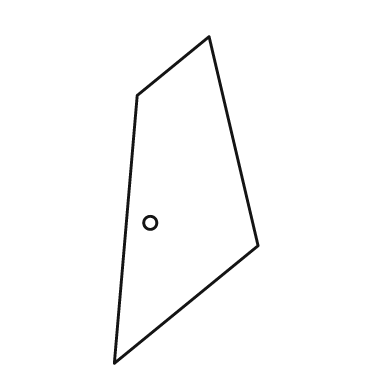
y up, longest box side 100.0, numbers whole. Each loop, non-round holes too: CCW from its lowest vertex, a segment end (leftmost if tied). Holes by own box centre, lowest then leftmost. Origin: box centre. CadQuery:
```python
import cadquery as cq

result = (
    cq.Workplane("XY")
    .moveTo(-22.0, -50.0)
    .lineTo(22.0, -14.0)
    .lineTo(7.0, 50.0)
    .lineTo(-15.0, 32.0)
    .close()
    .moveTo(-11.0, -7.0)
    .circle(2.0)
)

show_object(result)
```